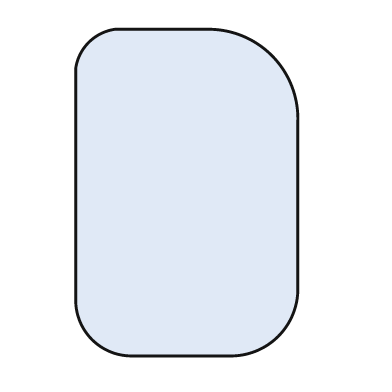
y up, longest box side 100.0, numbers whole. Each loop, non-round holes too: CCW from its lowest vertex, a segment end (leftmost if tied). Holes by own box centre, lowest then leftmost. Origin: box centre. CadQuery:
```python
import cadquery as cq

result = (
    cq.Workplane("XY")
    .moveTo(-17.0, -50.0)
    .lineTo(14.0, -50.0)
    .threePointArc((28.0, -44.0), (34.0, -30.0))
    .lineTo(34.0, 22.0)
    .threePointArc((26.0, 42.0), (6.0, 50.0))
    .lineTo(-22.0, 50.0)
    .threePointArc((-30.0, 46.0), (-34.0, 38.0))
    .lineTo(-34.0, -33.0)
    .threePointArc((-29.0, -45.0), (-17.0, -50.0))
    .close()
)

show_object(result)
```